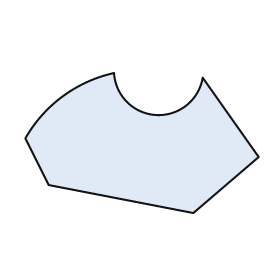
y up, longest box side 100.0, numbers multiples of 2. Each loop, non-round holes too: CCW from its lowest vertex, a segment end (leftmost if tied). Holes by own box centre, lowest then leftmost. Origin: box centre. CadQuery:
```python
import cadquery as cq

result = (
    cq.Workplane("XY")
    .moveTo(22.0, -30.0)
    .lineTo(50.0, -6.0)
    .lineTo(26.0, 28.0)
    .threePointArc((6.0, 12.0), (-12.0, 30.0))
    .threePointArc((-34.0, 20.0), (-50.0, 2.0))
    .lineTo(-40.0, -18.0)
    .close()
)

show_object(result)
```